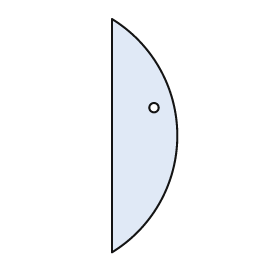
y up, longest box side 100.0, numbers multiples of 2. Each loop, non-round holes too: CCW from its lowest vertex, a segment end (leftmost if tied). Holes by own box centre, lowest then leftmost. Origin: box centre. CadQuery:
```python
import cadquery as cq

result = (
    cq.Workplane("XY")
    .moveTo(-14.0, -50.0)
    .threePointArc((14.0, 0.0), (-14.0, 50.0))
    .close()
    .moveTo(4.0, 12.0)
    .circle(2.0)
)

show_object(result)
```